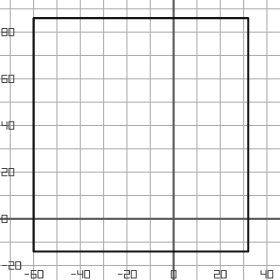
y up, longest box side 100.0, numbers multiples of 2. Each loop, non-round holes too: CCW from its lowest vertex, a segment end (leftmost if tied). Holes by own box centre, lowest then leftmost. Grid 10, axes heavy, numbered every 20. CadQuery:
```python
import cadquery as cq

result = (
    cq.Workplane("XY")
    .moveTo(-60.0, -14.0)
    .lineTo(32.0, -14.0)
    .lineTo(32.0, 86.0)
    .lineTo(-60.0, 86.0)
    .close()
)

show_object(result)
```